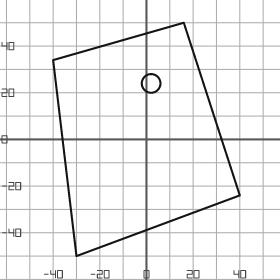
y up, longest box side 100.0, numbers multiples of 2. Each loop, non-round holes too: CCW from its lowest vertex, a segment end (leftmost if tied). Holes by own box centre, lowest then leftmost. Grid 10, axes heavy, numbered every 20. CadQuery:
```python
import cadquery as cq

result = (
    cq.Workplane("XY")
    .moveTo(-30.0, -50.0)
    .lineTo(40.0, -24.0)
    .lineTo(16.0, 50.0)
    .lineTo(-40.0, 34.0)
    .close()
    .moveTo(2.0, 24.0)
    .circle(4.0)
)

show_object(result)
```